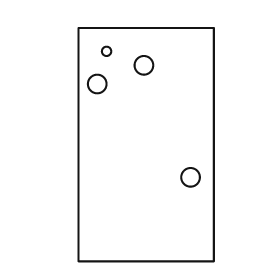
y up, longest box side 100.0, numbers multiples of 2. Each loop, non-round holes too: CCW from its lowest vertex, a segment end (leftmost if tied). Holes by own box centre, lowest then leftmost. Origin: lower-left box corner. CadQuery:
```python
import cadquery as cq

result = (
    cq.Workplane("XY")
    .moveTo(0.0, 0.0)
    .lineTo(58.0, 0.0)
    .lineTo(58.0, 100.0)
    .lineTo(0.0, 100.0)
    .close()
    .moveTo(48.0, 36.0)
    .circle(4.0)
    .moveTo(8.0, 76.0)
    .circle(4.0)
    .moveTo(28.0, 84.0)
    .circle(4.0)
    .moveTo(12.0, 90.0)
    .circle(2.0)
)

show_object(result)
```